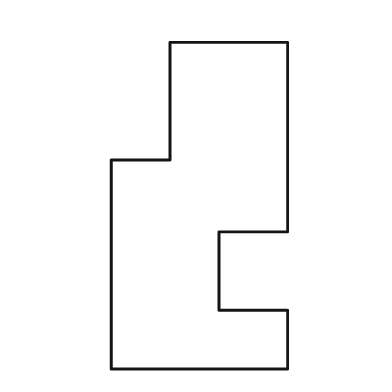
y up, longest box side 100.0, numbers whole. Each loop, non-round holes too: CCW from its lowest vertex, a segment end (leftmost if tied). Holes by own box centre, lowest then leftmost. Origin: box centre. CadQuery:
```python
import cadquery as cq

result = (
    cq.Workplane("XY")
    .moveTo(-27.0, -50.0)
    .lineTo(27.0, -50.0)
    .lineTo(27.0, -32.0)
    .lineTo(6.0, -32.0)
    .lineTo(6.0, -8.0)
    .lineTo(27.0, -8.0)
    .lineTo(27.0, 50.0)
    .lineTo(-9.0, 50.0)
    .lineTo(-9.0, 14.0)
    .lineTo(-27.0, 14.0)
    .close()
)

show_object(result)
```